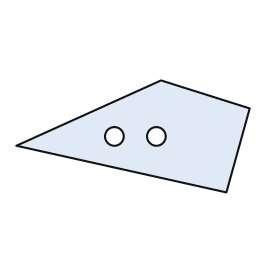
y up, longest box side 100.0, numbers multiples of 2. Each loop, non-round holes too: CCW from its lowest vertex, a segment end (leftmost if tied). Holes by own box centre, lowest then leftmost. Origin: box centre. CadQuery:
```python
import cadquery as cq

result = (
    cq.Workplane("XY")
    .moveTo(40.0, -24.0)
    .lineTo(50.0, 12.0)
    .lineTo(12.0, 24.0)
    .lineTo(-50.0, -4.0)
    .close()
    .moveTo(-8.0, 0.0)
    .circle(4.0)
    .moveTo(10.0, 0.0)
    .circle(4.0)
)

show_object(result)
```